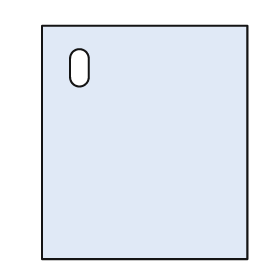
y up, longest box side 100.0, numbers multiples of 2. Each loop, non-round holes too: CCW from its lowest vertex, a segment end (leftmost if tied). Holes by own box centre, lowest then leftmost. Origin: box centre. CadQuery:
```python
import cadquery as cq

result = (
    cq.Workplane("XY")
    .moveTo(-44.0, -50.0)
    .lineTo(44.0, -50.0)
    .lineTo(44.0, 50.0)
    .lineTo(-44.0, 50.0)
    .close()
    .moveTo(-32.0, 28.0)
    .threePointArc((-28.0, 24.0), (-24.0, 28.0))
    .lineTo(-24.0, 36.0)
    .threePointArc((-28.0, 40.0), (-32.0, 36.0))
    .close()
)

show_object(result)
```